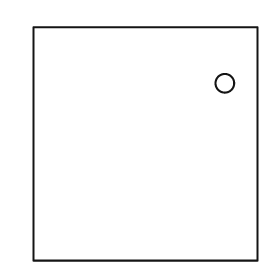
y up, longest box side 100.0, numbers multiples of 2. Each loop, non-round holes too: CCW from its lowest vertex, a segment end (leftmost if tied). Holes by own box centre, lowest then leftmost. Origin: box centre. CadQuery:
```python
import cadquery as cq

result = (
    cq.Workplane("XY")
    .moveTo(-48.0, -50.0)
    .lineTo(48.0, -50.0)
    .lineTo(48.0, 50.0)
    .lineTo(-48.0, 50.0)
    .close()
    .moveTo(34.0, 26.0)
    .circle(4.0)
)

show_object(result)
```